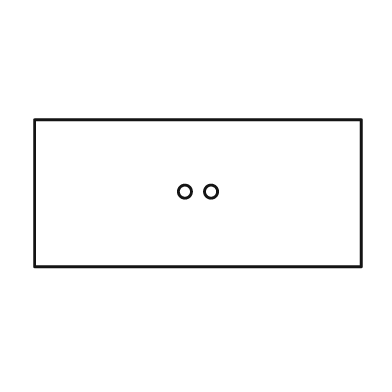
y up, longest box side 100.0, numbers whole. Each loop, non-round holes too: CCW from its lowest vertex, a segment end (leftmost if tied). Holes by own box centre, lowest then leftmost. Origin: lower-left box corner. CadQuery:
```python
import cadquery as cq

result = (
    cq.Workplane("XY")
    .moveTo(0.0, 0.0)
    .lineTo(100.0, 0.0)
    .lineTo(100.0, 45.0)
    .lineTo(0.0, 45.0)
    .close()
    .moveTo(46.0, 23.0)
    .circle(2.0)
    .moveTo(54.0, 23.0)
    .circle(2.0)
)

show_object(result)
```